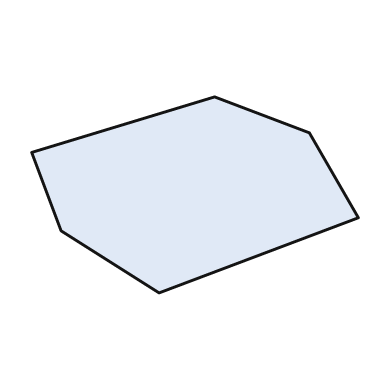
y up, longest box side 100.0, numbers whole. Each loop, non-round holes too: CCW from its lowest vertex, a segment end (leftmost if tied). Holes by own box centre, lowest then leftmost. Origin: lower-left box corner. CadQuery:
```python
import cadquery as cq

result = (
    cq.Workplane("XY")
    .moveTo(39.0, 0.0)
    .lineTo(100.0, 23.0)
    .lineTo(85.0, 49.0)
    .lineTo(56.0, 60.0)
    .lineTo(0.0, 43.0)
    .lineTo(9.0, 19.0)
    .close()
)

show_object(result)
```